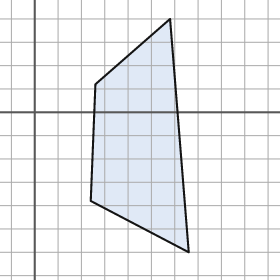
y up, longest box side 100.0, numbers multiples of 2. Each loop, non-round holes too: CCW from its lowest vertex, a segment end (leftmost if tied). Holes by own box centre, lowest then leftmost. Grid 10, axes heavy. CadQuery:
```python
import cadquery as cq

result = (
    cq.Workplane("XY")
    .moveTo(66.0, -60.0)
    .lineTo(58.0, 40.0)
    .lineTo(26.0, 12.0)
    .lineTo(24.0, -38.0)
    .close()
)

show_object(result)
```